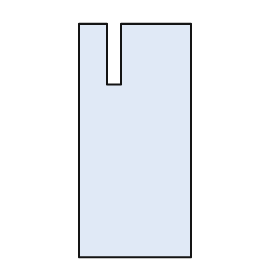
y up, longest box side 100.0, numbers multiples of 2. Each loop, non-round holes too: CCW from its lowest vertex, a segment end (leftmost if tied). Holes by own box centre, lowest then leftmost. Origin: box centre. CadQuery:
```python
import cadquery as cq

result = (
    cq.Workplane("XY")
    .moveTo(-24.0, -50.0)
    .lineTo(24.0, -50.0)
    .lineTo(24.0, 50.0)
    .lineTo(-6.0, 50.0)
    .lineTo(-6.0, 24.0)
    .lineTo(-12.0, 24.0)
    .lineTo(-12.0, 50.0)
    .lineTo(-24.0, 50.0)
    .close()
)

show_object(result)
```